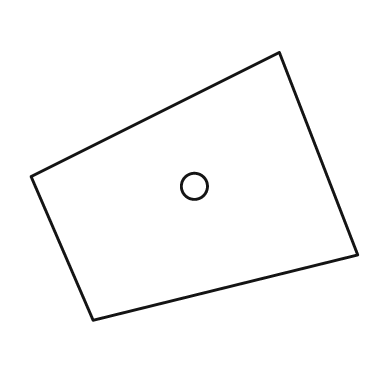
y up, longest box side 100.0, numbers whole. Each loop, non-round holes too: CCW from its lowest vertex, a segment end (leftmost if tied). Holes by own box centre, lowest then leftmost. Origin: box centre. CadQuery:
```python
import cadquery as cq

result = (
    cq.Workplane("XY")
    .moveTo(-31.0, -41.0)
    .lineTo(50.0, -21.0)
    .lineTo(26.0, 41.0)
    .lineTo(-50.0, 3.0)
    .close()
    .moveTo(0.0, 0.0)
    .circle(4.0)
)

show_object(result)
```